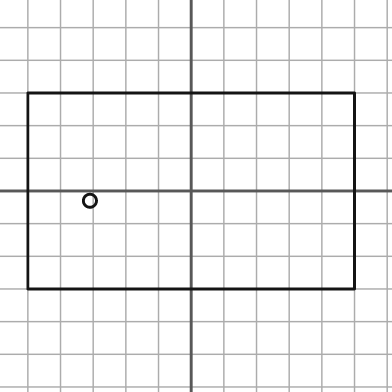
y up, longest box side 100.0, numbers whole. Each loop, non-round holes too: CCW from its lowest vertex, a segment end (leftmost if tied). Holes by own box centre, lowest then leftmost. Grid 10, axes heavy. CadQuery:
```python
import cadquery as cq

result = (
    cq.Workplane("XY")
    .moveTo(-50.0, -30.0)
    .lineTo(50.0, -30.0)
    .lineTo(50.0, 30.0)
    .lineTo(-50.0, 30.0)
    .close()
    .moveTo(-31.0, -3.0)
    .circle(2.0)
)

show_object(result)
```